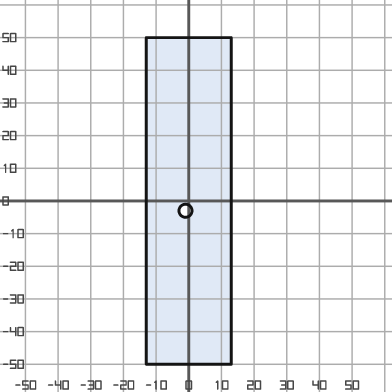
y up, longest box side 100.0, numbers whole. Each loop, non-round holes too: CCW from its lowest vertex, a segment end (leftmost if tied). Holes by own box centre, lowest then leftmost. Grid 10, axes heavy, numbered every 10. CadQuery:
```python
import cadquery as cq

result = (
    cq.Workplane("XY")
    .moveTo(-13.0, -50.0)
    .lineTo(13.0, -50.0)
    .lineTo(13.0, 50.0)
    .lineTo(-13.0, 50.0)
    .close()
    .moveTo(-1.0, -3.0)
    .circle(2.0)
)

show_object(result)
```